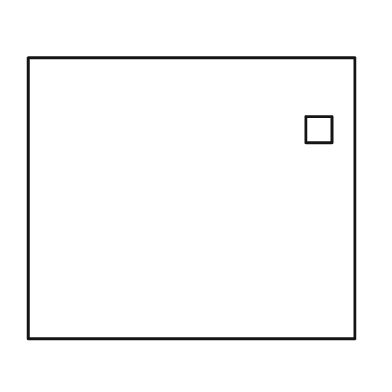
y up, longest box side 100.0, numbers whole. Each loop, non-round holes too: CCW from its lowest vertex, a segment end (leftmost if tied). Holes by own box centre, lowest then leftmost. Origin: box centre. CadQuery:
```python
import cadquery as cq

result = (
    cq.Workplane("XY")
    .moveTo(-50.0, -43.0)
    .lineTo(50.0, -43.0)
    .lineTo(50.0, 43.0)
    .lineTo(-50.0, 43.0)
    .close()
    .moveTo(35.0, 17.0)
    .lineTo(43.0, 17.0)
    .lineTo(43.0, 25.0)
    .lineTo(35.0, 25.0)
    .close()
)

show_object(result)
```